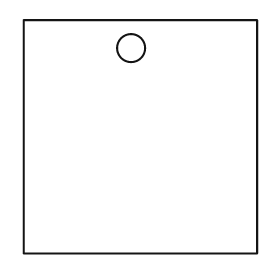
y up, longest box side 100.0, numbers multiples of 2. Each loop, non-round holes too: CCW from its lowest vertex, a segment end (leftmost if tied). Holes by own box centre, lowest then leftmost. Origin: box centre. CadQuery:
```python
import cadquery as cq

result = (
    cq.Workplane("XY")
    .moveTo(-50.0, -50.0)
    .lineTo(50.0, -50.0)
    .lineTo(50.0, 50.0)
    .lineTo(-50.0, 50.0)
    .close()
    .moveTo(-4.0, 38.0)
    .circle(6.0)
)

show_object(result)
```